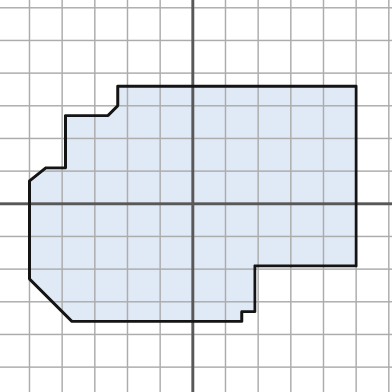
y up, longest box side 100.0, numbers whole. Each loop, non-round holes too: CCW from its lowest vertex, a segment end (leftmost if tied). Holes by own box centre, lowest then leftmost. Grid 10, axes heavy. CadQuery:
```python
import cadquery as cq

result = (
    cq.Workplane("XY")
    .moveTo(-37.0, -36.0)
    .lineTo(15.0, -36.0)
    .lineTo(15.0, -33.0)
    .lineTo(19.0, -33.0)
    .lineTo(19.0, -19.0)
    .lineTo(50.0, -19.0)
    .lineTo(50.0, 36.0)
    .lineTo(-23.0, 36.0)
    .lineTo(-23.0, 30.0)
    .lineTo(-26.0, 27.0)
    .lineTo(-39.0, 27.0)
    .lineTo(-39.0, 11.0)
    .lineTo(-45.0, 11.0)
    .lineTo(-50.0, 7.0)
    .lineTo(-50.0, -23.0)
    .close()
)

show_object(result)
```